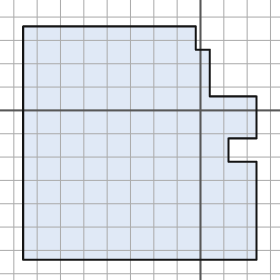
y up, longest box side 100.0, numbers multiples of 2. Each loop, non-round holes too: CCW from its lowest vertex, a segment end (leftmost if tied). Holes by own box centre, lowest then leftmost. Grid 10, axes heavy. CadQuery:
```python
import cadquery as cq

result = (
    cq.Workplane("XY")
    .moveTo(-76.0, -64.0)
    .lineTo(24.0, -64.0)
    .lineTo(24.0, -22.0)
    .lineTo(12.0, -22.0)
    .lineTo(12.0, -12.0)
    .lineTo(24.0, -12.0)
    .lineTo(24.0, 6.0)
    .lineTo(4.0, 6.0)
    .lineTo(4.0, 26.0)
    .lineTo(-2.0, 26.0)
    .lineTo(-2.0, 36.0)
    .lineTo(-76.0, 36.0)
    .close()
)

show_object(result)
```